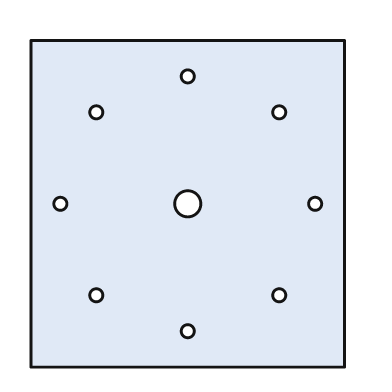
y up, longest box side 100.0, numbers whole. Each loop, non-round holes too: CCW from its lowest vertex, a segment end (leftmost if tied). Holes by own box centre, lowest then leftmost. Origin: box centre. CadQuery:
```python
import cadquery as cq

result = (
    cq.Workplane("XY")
    .moveTo(-48.0, -50.0)
    .lineTo(48.0, -50.0)
    .lineTo(48.0, 50.0)
    .lineTo(-48.0, 50.0)
    .close()
    .moveTo(0.0, -39.0)
    .circle(2.0)
    .moveTo(-28.0, -28.0)
    .circle(2.0)
    .moveTo(28.0, -28.0)
    .circle(2.0)
    .moveTo(-39.0, 0.0)
    .circle(2.0)
    .moveTo(0.0, 0.0)
    .circle(4.0)
    .moveTo(39.0, 0.0)
    .circle(2.0)
    .moveTo(-28.0, 28.0)
    .circle(2.0)
    .moveTo(28.0, 28.0)
    .circle(2.0)
    .moveTo(0.0, 39.0)
    .circle(2.0)
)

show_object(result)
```